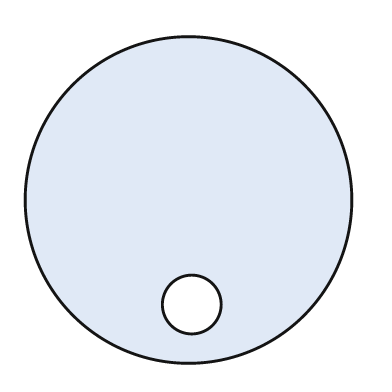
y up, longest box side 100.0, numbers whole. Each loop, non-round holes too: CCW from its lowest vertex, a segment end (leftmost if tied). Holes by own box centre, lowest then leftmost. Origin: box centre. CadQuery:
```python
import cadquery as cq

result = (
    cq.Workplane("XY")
    .moveTo(0.0, 0.0)
    .circle(50.0)
    .moveTo(1.0, -32.0)
    .circle(9.0)
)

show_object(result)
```